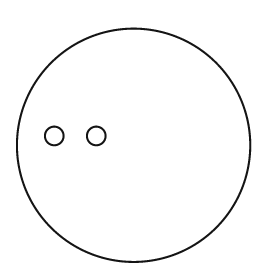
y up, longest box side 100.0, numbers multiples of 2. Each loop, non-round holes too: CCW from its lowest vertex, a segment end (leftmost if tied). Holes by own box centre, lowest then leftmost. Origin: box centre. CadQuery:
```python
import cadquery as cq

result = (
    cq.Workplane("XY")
    .moveTo(0.0, 0.0)
    .circle(50.0)
    .moveTo(-34.0, 4.0)
    .circle(4.0)
    .moveTo(-16.0, 4.0)
    .circle(4.0)
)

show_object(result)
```